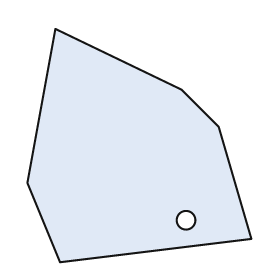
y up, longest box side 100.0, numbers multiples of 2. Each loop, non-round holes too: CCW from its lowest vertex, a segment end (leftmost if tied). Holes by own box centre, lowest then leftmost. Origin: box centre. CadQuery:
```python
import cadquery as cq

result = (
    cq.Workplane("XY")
    .moveTo(-34.0, -50.0)
    .lineTo(48.0, -40.0)
    .lineTo(34.0, 8.0)
    .lineTo(18.0, 24.0)
    .lineTo(-36.0, 50.0)
    .lineTo(-48.0, -16.0)
    .close()
    .moveTo(20.0, -32.0)
    .circle(4.0)
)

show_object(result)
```